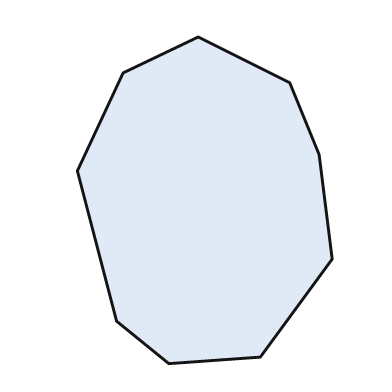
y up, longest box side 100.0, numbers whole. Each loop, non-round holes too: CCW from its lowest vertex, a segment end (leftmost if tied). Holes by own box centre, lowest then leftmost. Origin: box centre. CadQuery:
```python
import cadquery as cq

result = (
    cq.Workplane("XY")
    .moveTo(-11.0, -50.0)
    .lineTo(17.0, -48.0)
    .lineTo(39.0, -18.0)
    .lineTo(35.0, 14.0)
    .lineTo(26.0, 36.0)
    .lineTo(-2.0, 50.0)
    .lineTo(-25.0, 39.0)
    .lineTo(-39.0, 9.0)
    .lineTo(-27.0, -37.0)
    .close()
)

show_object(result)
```